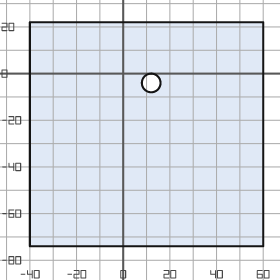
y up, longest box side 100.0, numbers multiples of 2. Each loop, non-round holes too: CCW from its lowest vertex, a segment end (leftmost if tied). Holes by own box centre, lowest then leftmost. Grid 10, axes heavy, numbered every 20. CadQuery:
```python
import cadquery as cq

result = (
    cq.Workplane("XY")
    .moveTo(-40.0, -74.0)
    .lineTo(60.0, -74.0)
    .lineTo(60.0, 22.0)
    .lineTo(-40.0, 22.0)
    .close()
    .moveTo(12.0, -4.0)
    .circle(4.0)
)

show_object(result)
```